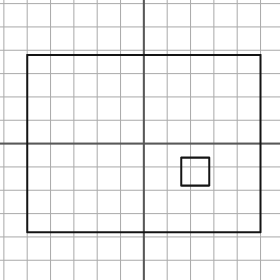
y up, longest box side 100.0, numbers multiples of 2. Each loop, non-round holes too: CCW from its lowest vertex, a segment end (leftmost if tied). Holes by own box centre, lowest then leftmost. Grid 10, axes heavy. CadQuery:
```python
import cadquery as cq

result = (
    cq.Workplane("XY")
    .moveTo(-50.0, -38.0)
    .lineTo(50.0, -38.0)
    .lineTo(50.0, 38.0)
    .lineTo(-50.0, 38.0)
    .close()
    .moveTo(16.0, -18.0)
    .lineTo(28.0, -18.0)
    .lineTo(28.0, -6.0)
    .lineTo(16.0, -6.0)
    .close()
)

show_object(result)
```